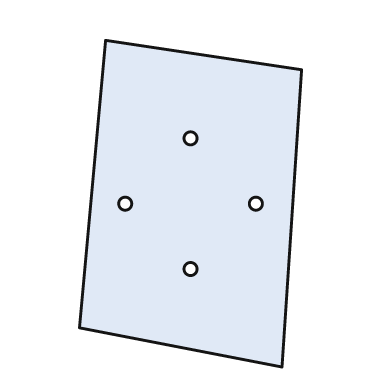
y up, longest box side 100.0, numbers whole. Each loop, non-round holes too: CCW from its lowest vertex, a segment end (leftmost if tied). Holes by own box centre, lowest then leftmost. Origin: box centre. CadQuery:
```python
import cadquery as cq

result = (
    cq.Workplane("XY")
    .moveTo(28.0, -50.0)
    .lineTo(34.0, 41.0)
    .lineTo(-26.0, 50.0)
    .lineTo(-34.0, -38.0)
    .close()
    .moveTo(0.0, -20.0)
    .circle(2.0)
    .moveTo(-20.0, 0.0)
    .circle(2.0)
    .moveTo(20.0, 0.0)
    .circle(2.0)
    .moveTo(0.0, 20.0)
    .circle(2.0)
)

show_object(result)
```